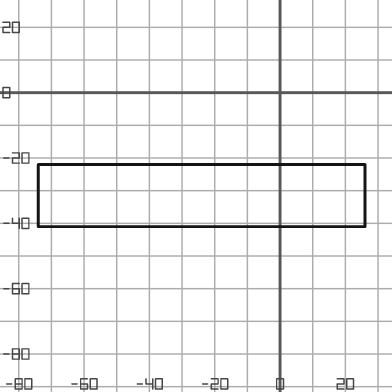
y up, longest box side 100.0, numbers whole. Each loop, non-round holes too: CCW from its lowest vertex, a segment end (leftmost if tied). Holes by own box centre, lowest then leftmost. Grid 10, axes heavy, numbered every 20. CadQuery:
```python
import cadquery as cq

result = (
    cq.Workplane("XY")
    .moveTo(-74.0, -41.0)
    .lineTo(26.0, -41.0)
    .lineTo(26.0, -22.0)
    .lineTo(-74.0, -22.0)
    .close()
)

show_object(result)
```